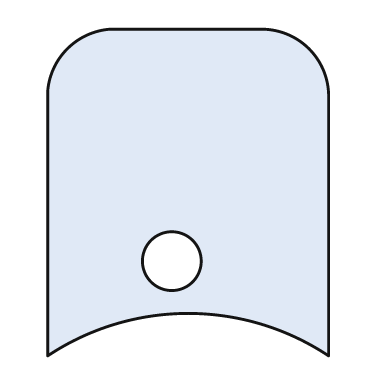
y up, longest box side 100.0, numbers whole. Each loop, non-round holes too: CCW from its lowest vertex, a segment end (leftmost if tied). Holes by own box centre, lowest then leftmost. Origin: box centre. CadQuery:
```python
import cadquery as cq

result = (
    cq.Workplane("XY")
    .moveTo(-43.0, -50.0)
    .threePointArc((0.0, -37.0), (43.0, -50.0))
    .lineTo(43.0, 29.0)
    .threePointArc((37.0, 44.0), (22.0, 50.0))
    .lineTo(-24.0, 50.0)
    .threePointArc((-37.0, 44.0), (-43.0, 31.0))
    .close()
    .moveTo(-5.0, -21.0)
    .circle(9.0)
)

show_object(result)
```